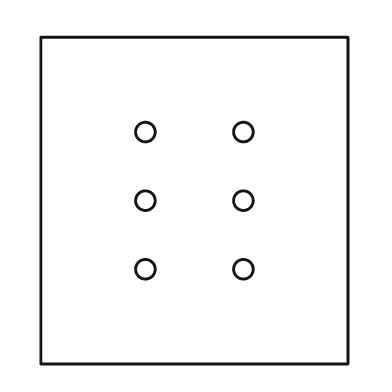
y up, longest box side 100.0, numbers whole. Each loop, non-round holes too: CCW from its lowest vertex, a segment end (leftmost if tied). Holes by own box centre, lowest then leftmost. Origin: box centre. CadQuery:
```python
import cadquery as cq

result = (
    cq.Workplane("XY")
    .moveTo(-47.0, -50.0)
    .lineTo(47.0, -50.0)
    .lineTo(47.0, 50.0)
    .lineTo(-47.0, 50.0)
    .close()
    .moveTo(-15.0, -21.0)
    .circle(3.0)
    .moveTo(15.0, -21.0)
    .circle(3.0)
    .moveTo(-15.0, 0.0)
    .circle(3.0)
    .moveTo(15.0, 0.0)
    .circle(3.0)
    .moveTo(-15.0, 21.0)
    .circle(3.0)
    .moveTo(15.0, 21.0)
    .circle(3.0)
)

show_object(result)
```